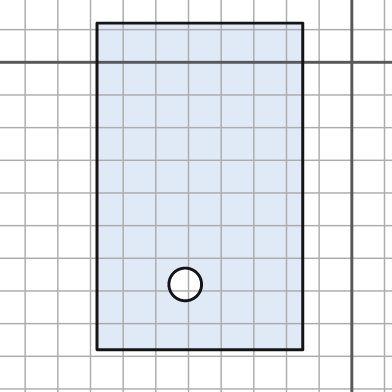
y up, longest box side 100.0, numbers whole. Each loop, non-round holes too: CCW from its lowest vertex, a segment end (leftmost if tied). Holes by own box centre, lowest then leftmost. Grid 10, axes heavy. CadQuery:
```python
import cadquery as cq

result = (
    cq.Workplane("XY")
    .moveTo(-78.0, -88.0)
    .lineTo(-15.0, -88.0)
    .lineTo(-15.0, 12.0)
    .lineTo(-78.0, 12.0)
    .close()
    .moveTo(-51.0, -68.0)
    .circle(5.0)
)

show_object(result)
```